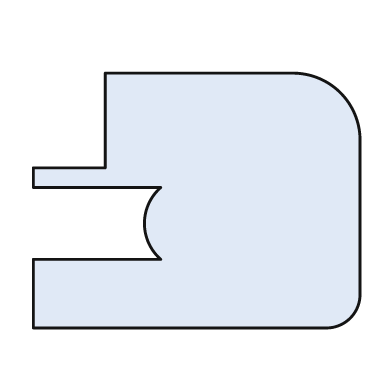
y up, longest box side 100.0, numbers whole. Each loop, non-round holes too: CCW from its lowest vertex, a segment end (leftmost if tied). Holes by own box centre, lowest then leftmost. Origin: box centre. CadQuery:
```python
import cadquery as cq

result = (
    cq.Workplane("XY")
    .moveTo(-50.0, -39.0)
    .lineTo(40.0, -39.0)
    .threePointArc((47.0, -36.0), (50.0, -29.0))
    .lineTo(50.0, 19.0)
    .threePointArc((44.0, 33.0), (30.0, 39.0))
    .lineTo(-28.0, 39.0)
    .lineTo(-28.0, 10.0)
    .lineTo(-50.0, 10.0)
    .lineTo(-50.0, 4.0)
    .lineTo(-11.0, 4.0)
    .threePointArc((-16.0, -7.0), (-11.0, -18.0))
    .lineTo(-50.0, -18.0)
    .close()
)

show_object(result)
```